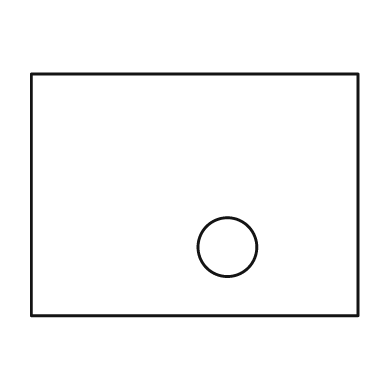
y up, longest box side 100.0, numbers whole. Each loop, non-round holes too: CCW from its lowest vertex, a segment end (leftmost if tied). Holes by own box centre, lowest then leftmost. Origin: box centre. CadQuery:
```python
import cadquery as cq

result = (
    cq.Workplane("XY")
    .moveTo(-50.0, -37.0)
    .lineTo(50.0, -37.0)
    .lineTo(50.0, 37.0)
    .lineTo(-50.0, 37.0)
    .close()
    .moveTo(10.0, -16.0)
    .circle(9.0)
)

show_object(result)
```